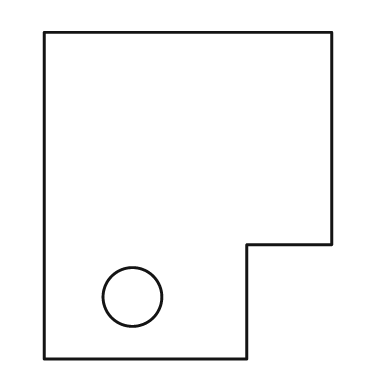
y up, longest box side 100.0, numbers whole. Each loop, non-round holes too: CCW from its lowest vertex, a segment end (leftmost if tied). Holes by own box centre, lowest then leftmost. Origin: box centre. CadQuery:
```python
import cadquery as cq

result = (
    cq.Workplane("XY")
    .moveTo(-44.0, -50.0)
    .lineTo(18.0, -50.0)
    .lineTo(18.0, -15.0)
    .lineTo(44.0, -15.0)
    .lineTo(44.0, 50.0)
    .lineTo(-44.0, 50.0)
    .close()
    .moveTo(-17.0, -31.0)
    .circle(9.0)
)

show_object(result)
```